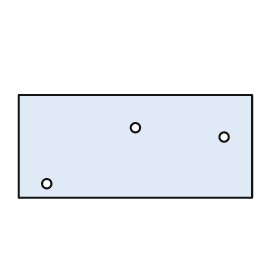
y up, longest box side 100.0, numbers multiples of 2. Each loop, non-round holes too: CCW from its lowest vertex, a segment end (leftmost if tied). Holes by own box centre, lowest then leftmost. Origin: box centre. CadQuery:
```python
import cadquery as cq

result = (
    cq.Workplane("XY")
    .moveTo(-50.0, -22.0)
    .lineTo(50.0, -22.0)
    .lineTo(50.0, 22.0)
    .lineTo(-50.0, 22.0)
    .close()
    .moveTo(-38.0, -16.0)
    .circle(2.0)
    .moveTo(38.0, 4.0)
    .circle(2.0)
    .moveTo(0.0, 8.0)
    .circle(2.0)
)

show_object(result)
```